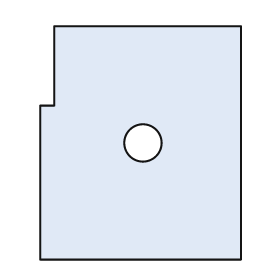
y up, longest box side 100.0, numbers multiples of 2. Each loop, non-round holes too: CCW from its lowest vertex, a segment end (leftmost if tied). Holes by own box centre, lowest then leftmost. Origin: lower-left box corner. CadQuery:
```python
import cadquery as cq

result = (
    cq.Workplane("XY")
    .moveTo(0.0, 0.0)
    .lineTo(86.0, 0.0)
    .lineTo(86.0, 100.0)
    .lineTo(6.0, 100.0)
    .lineTo(6.0, 66.0)
    .lineTo(0.0, 66.0)
    .close()
    .moveTo(44.0, 50.0)
    .circle(8.0)
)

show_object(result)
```